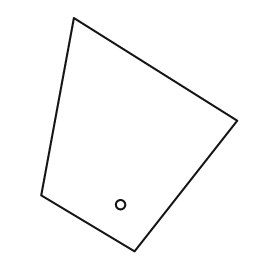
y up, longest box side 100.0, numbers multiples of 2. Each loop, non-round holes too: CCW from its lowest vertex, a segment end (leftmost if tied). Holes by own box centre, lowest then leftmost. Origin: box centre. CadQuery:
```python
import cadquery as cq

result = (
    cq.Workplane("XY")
    .moveTo(-2.0, -50.0)
    .lineTo(42.0, 6.0)
    .lineTo(-28.0, 50.0)
    .lineTo(-42.0, -26.0)
    .close()
    .moveTo(-8.0, -30.0)
    .circle(2.0)
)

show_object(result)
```